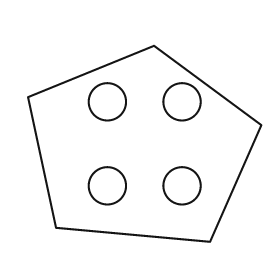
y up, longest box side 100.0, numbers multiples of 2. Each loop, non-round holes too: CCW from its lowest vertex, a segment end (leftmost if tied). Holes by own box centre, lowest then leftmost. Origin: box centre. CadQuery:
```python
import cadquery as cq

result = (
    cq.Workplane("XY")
    .moveTo(28.0, -42.0)
    .lineTo(50.0, 8.0)
    .lineTo(4.0, 42.0)
    .lineTo(-50.0, 20.0)
    .lineTo(-38.0, -36.0)
    .close()
    .moveTo(-16.0, -18.0)
    .circle(8.0)
    .moveTo(16.0, -18.0)
    .circle(8.0)
    .moveTo(-16.0, 18.0)
    .circle(8.0)
    .moveTo(16.0, 18.0)
    .circle(8.0)
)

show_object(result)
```